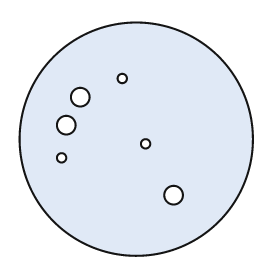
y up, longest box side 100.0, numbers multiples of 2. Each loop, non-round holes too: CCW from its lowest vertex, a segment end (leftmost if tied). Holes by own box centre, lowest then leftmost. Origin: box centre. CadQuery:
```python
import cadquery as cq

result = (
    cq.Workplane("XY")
    .moveTo(0.0, 0.0)
    .circle(50.0)
    .moveTo(16.0, -24.0)
    .circle(4.0)
    .moveTo(-32.0, -8.0)
    .circle(2.0)
    .moveTo(4.0, -2.0)
    .circle(2.0)
    .moveTo(-30.0, 6.0)
    .circle(4.0)
    .moveTo(-24.0, 18.0)
    .circle(4.0)
    .moveTo(-6.0, 26.0)
    .circle(2.0)
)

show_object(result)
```